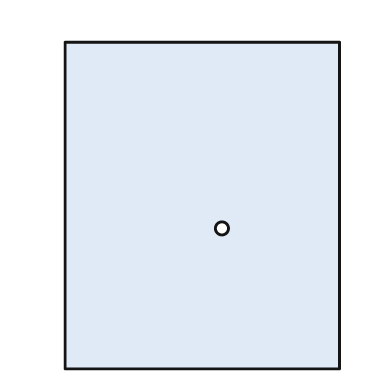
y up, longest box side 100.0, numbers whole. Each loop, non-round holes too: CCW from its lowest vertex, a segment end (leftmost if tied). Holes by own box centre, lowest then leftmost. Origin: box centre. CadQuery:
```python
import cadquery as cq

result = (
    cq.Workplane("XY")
    .moveTo(-42.0, -50.0)
    .lineTo(42.0, -50.0)
    .lineTo(42.0, 50.0)
    .lineTo(-42.0, 50.0)
    .close()
    .moveTo(6.0, -7.0)
    .circle(2.0)
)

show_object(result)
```